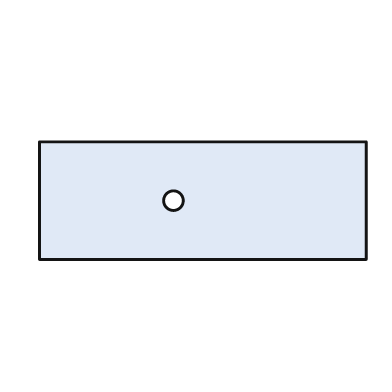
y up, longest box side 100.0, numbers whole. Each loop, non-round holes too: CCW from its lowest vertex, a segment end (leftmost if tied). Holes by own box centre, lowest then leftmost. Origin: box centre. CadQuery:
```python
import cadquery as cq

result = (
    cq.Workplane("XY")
    .moveTo(-50.0, -18.0)
    .lineTo(50.0, -18.0)
    .lineTo(50.0, 18.0)
    .lineTo(-50.0, 18.0)
    .close()
    .moveTo(-9.0, 0.0)
    .circle(3.0)
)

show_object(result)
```